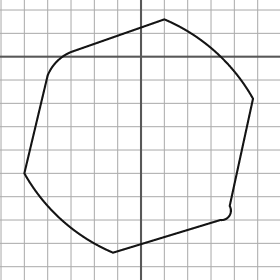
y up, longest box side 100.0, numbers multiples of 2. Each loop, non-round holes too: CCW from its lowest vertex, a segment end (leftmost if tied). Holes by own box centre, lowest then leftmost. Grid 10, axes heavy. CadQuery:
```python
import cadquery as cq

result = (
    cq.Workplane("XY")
    .moveTo(-12.0, -84.0)
    .lineTo(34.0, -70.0)
    .threePointArc((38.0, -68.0), (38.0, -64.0))
    .lineTo(48.0, -18.0)
    .threePointArc((32.0, 2.0), (10.0, 16.0))
    .lineTo(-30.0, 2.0)
    .threePointArc((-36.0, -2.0), (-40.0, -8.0))
    .lineTo(-50.0, -50.0)
    .threePointArc((-34.0, -70.0), (-12.0, -84.0))
    .close()
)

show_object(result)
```